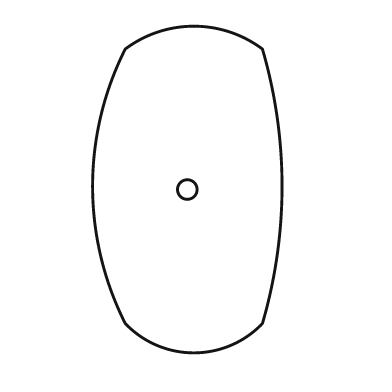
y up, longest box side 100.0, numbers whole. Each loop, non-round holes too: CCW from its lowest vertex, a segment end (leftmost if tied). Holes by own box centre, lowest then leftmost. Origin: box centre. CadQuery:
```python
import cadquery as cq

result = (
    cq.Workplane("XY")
    .moveTo(-19.0, -41.0)
    .threePointArc((2.0, -50.0), (23.0, -41.0))
    .threePointArc((29.0, 1.0), (23.0, 43.0))
    .threePointArc((2.0, 50.0), (-19.0, 43.0))
    .threePointArc((-29.0, 1.0), (-19.0, -41.0))
    .close()
    .moveTo(0.0, 0.0)
    .circle(3.0)
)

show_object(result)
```